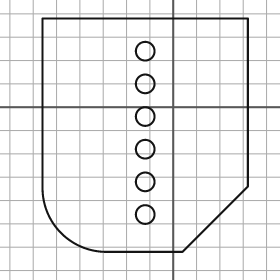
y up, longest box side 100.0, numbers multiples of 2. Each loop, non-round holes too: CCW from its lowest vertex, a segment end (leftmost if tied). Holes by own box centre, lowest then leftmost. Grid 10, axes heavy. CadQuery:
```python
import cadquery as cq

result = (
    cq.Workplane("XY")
    .moveTo(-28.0, -62.0)
    .lineTo(4.0, -62.0)
    .lineTo(32.0, -34.0)
    .lineTo(32.0, 38.0)
    .lineTo(-56.0, 38.0)
    .lineTo(-56.0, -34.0)
    .threePointArc((-48.0, -54.0), (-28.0, -62.0))
    .close()
    .moveTo(-12.0, -46.0)
    .circle(4.0)
    .moveTo(-12.0, -32.0)
    .circle(4.0)
    .moveTo(-12.0, -18.0)
    .circle(4.0)
    .moveTo(-12.0, -4.0)
    .circle(4.0)
    .moveTo(-12.0, 10.0)
    .circle(4.0)
    .moveTo(-12.0, 24.0)
    .circle(4.0)
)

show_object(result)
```